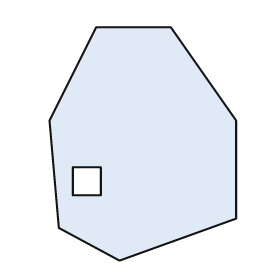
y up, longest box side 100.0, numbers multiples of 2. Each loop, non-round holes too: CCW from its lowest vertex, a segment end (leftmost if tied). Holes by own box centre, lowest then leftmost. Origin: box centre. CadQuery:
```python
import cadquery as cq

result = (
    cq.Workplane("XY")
    .moveTo(-10.0, -50.0)
    .lineTo(40.0, -32.0)
    .lineTo(40.0, 10.0)
    .lineTo(12.0, 50.0)
    .lineTo(-20.0, 50.0)
    .lineTo(-40.0, 10.0)
    .lineTo(-36.0, -36.0)
    .close()
    .moveTo(-30.0, -22.0)
    .lineTo(-18.0, -22.0)
    .lineTo(-18.0, -10.0)
    .lineTo(-30.0, -10.0)
    .close()
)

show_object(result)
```